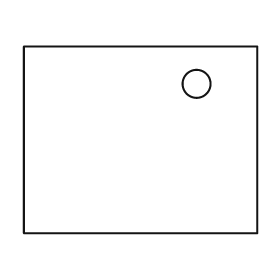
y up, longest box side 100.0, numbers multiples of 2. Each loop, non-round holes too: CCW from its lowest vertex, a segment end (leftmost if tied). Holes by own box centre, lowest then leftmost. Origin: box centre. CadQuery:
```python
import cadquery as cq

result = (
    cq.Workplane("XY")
    .moveTo(-50.0, -40.0)
    .lineTo(50.0, -40.0)
    .lineTo(50.0, 40.0)
    .lineTo(-50.0, 40.0)
    .close()
    .moveTo(24.0, 24.0)
    .circle(6.0)
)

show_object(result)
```